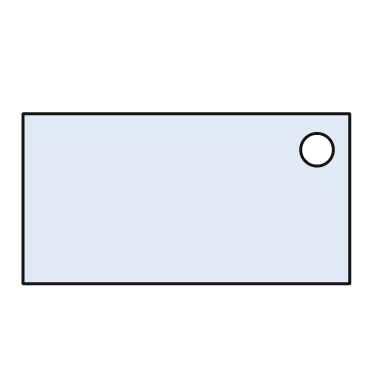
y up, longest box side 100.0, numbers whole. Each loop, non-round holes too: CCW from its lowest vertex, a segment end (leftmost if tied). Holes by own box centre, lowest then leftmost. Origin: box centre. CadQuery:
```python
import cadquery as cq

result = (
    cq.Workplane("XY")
    .moveTo(-50.0, -26.0)
    .lineTo(50.0, -26.0)
    .lineTo(50.0, 26.0)
    .lineTo(-50.0, 26.0)
    .close()
    .moveTo(40.0, 15.0)
    .circle(5.0)
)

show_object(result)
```